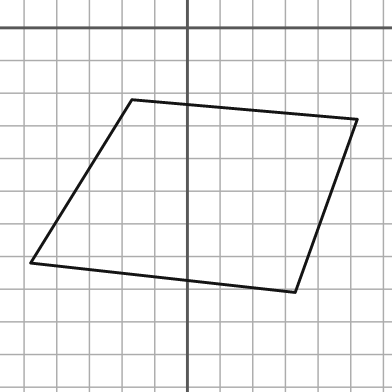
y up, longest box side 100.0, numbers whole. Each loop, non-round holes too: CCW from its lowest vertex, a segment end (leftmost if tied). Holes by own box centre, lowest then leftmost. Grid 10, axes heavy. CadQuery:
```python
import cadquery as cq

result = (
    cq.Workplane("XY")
    .moveTo(33.0, -81.0)
    .lineTo(52.0, -28.0)
    .lineTo(-17.0, -22.0)
    .lineTo(-48.0, -72.0)
    .close()
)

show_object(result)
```